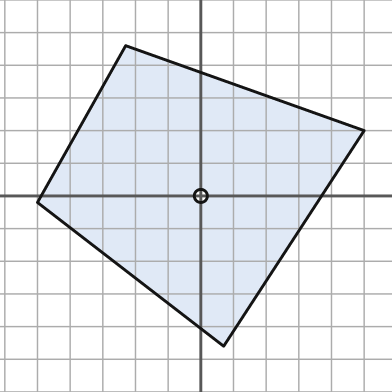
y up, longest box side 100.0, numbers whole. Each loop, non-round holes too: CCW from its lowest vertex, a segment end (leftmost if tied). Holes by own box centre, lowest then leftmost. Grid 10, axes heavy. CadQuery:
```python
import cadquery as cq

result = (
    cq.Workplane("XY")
    .moveTo(7.0, -46.0)
    .lineTo(50.0, 20.0)
    .lineTo(-23.0, 46.0)
    .lineTo(-50.0, -2.0)
    .close()
    .moveTo(0.0, 0.0)
    .circle(2.0)
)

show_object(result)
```